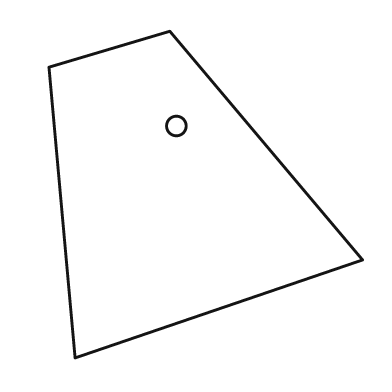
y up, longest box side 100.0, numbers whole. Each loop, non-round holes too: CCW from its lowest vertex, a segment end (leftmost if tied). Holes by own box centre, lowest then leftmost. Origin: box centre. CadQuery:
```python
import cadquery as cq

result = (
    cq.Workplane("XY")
    .moveTo(-40.0, -50.0)
    .lineTo(48.0, -20.0)
    .lineTo(-11.0, 50.0)
    .lineTo(-48.0, 39.0)
    .close()
    .moveTo(-9.0, 21.0)
    .circle(3.0)
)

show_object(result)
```